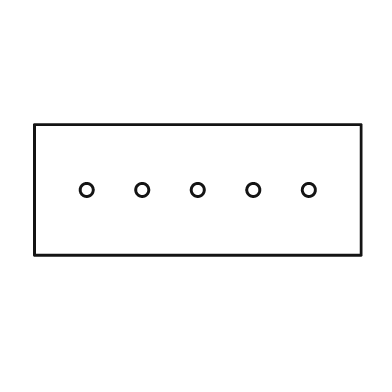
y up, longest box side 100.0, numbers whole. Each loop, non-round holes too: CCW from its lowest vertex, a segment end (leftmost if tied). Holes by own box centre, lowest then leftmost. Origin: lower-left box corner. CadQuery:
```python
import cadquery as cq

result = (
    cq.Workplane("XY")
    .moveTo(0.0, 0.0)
    .lineTo(100.0, 0.0)
    .lineTo(100.0, 40.0)
    .lineTo(0.0, 40.0)
    .close()
    .moveTo(16.0, 20.0)
    .circle(2.0)
    .moveTo(33.0, 20.0)
    .circle(2.0)
    .moveTo(50.0, 20.0)
    .circle(2.0)
    .moveTo(67.0, 20.0)
    .circle(2.0)
    .moveTo(84.0, 20.0)
    .circle(2.0)
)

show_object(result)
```